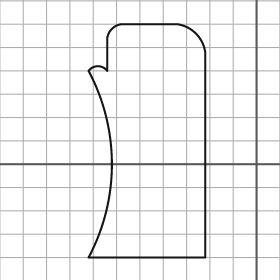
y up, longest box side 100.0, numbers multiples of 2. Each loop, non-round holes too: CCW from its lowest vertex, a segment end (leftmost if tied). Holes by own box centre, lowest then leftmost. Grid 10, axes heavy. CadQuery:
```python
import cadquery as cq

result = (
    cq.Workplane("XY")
    .moveTo(-72.0, -40.0)
    .lineTo(-22.0, -40.0)
    .lineTo(-22.0, 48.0)
    .threePointArc((-26.0, 56.0), (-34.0, 60.0))
    .lineTo(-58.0, 60.0)
    .threePointArc((-62.0, 58.0), (-64.0, 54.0))
    .lineTo(-64.0, 40.0)
    .threePointArc((-68.0, 42.0), (-72.0, 40.0))
    .threePointArc((-62.0, 0.0), (-72.0, -40.0))
    .close()
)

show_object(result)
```